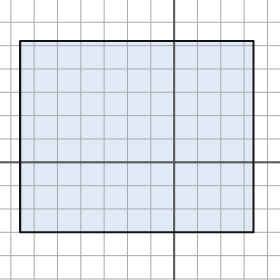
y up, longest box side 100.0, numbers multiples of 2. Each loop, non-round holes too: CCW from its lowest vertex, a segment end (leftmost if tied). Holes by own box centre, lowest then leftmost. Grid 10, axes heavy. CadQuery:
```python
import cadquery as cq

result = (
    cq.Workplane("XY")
    .moveTo(-66.0, -30.0)
    .lineTo(34.0, -30.0)
    .lineTo(34.0, 52.0)
    .lineTo(-66.0, 52.0)
    .close()
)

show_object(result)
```